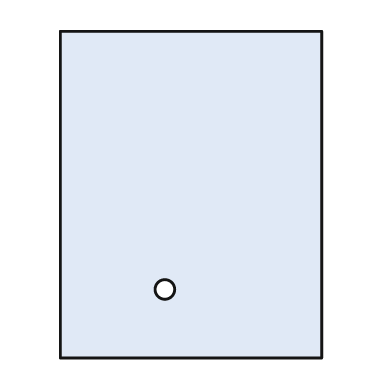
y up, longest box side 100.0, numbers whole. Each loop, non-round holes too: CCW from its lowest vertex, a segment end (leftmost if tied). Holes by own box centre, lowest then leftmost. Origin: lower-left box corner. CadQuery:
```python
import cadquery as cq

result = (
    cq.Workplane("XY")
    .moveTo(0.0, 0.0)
    .lineTo(80.0, 0.0)
    .lineTo(80.0, 100.0)
    .lineTo(0.0, 100.0)
    .close()
    .moveTo(32.0, 21.0)
    .circle(3.0)
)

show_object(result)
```